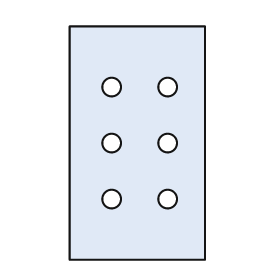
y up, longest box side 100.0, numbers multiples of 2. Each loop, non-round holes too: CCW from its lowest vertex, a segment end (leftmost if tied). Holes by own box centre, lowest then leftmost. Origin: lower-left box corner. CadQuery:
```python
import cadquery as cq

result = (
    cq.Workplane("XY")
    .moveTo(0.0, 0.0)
    .lineTo(58.0, 0.0)
    .lineTo(58.0, 100.0)
    .lineTo(0.0, 100.0)
    .close()
    .moveTo(18.0, 26.0)
    .circle(4.0)
    .moveTo(42.0, 26.0)
    .circle(4.0)
    .moveTo(18.0, 50.0)
    .circle(4.0)
    .moveTo(42.0, 50.0)
    .circle(4.0)
    .moveTo(18.0, 74.0)
    .circle(4.0)
    .moveTo(42.0, 74.0)
    .circle(4.0)
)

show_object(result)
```